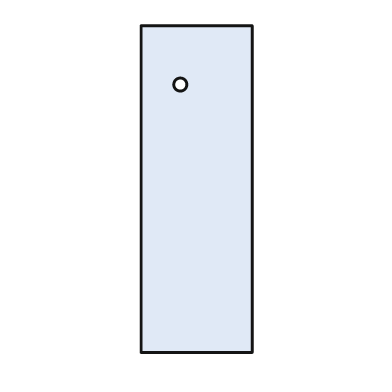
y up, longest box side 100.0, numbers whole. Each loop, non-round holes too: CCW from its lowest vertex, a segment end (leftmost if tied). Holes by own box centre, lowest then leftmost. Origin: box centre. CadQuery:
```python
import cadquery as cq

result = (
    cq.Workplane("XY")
    .moveTo(-17.0, -50.0)
    .lineTo(17.0, -50.0)
    .lineTo(17.0, 50.0)
    .lineTo(-17.0, 50.0)
    .close()
    .moveTo(-5.0, 32.0)
    .circle(2.0)
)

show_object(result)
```